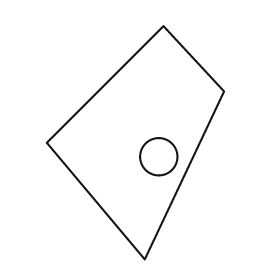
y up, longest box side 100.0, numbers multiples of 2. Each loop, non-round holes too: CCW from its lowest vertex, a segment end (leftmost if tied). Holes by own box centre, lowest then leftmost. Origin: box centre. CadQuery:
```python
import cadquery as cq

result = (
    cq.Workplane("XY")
    .moveTo(4.0, -50.0)
    .lineTo(38.0, 22.0)
    .lineTo(12.0, 50.0)
    .lineTo(-38.0, 0.0)
    .close()
    .moveTo(10.0, -6.0)
    .circle(8.0)
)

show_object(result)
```